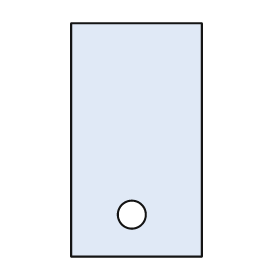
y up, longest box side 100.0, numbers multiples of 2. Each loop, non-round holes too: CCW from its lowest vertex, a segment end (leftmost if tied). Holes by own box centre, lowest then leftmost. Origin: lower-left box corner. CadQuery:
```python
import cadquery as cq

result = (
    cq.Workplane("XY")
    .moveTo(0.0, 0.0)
    .lineTo(56.0, 0.0)
    .lineTo(56.0, 100.0)
    .lineTo(0.0, 100.0)
    .close()
    .moveTo(26.0, 18.0)
    .circle(6.0)
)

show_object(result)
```